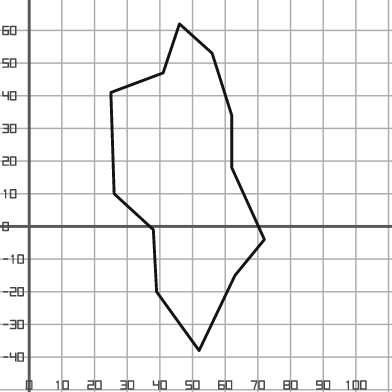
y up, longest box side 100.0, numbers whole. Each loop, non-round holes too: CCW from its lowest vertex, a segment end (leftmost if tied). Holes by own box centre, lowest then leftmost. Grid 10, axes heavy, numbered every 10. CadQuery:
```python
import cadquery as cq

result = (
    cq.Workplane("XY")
    .moveTo(52.0, -38.0)
    .lineTo(63.0, -15.0)
    .lineTo(72.0, -4.0)
    .lineTo(62.0, 18.0)
    .lineTo(62.0, 34.0)
    .lineTo(56.0, 53.0)
    .lineTo(46.0, 62.0)
    .lineTo(41.0, 47.0)
    .lineTo(25.0, 41.0)
    .lineTo(26.0, 10.0)
    .lineTo(38.0, -1.0)
    .lineTo(39.0, -20.0)
    .close()
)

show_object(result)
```